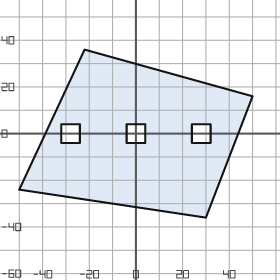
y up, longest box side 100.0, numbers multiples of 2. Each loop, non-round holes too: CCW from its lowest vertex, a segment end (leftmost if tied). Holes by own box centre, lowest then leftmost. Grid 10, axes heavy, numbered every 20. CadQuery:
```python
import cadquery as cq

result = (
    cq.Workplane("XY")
    .moveTo(30.0, -36.0)
    .lineTo(50.0, 16.0)
    .lineTo(-22.0, 36.0)
    .lineTo(-50.0, -24.0)
    .close()
    .moveTo(-32.0, -4.0)
    .lineTo(-24.0, -4.0)
    .lineTo(-24.0, 4.0)
    .lineTo(-32.0, 4.0)
    .close()
    .moveTo(-4.0, -4.0)
    .lineTo(4.0, -4.0)
    .lineTo(4.0, 4.0)
    .lineTo(-4.0, 4.0)
    .close()
    .moveTo(24.0, -4.0)
    .lineTo(32.0, -4.0)
    .lineTo(32.0, 4.0)
    .lineTo(24.0, 4.0)
    .close()
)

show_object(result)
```